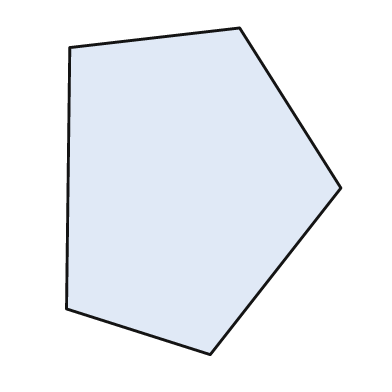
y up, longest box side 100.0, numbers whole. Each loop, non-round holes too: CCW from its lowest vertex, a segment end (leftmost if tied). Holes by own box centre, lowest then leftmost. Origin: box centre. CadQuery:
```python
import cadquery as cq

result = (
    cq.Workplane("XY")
    .moveTo(2.0, -50.0)
    .lineTo(42.0, 1.0)
    .lineTo(11.0, 50.0)
    .lineTo(-41.0, 44.0)
    .lineTo(-42.0, -36.0)
    .close()
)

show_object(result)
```